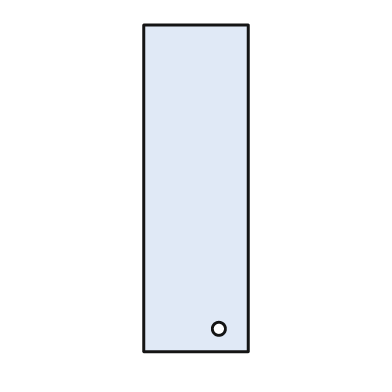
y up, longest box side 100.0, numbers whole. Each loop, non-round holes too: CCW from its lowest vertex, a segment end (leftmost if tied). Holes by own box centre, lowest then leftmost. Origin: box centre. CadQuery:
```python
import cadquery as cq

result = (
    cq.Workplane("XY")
    .moveTo(-16.0, -50.0)
    .lineTo(16.0, -50.0)
    .lineTo(16.0, 50.0)
    .lineTo(-16.0, 50.0)
    .close()
    .moveTo(7.0, -43.0)
    .circle(2.0)
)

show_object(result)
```